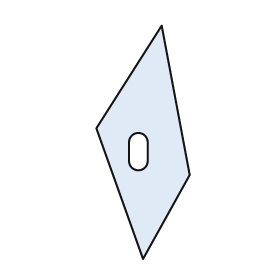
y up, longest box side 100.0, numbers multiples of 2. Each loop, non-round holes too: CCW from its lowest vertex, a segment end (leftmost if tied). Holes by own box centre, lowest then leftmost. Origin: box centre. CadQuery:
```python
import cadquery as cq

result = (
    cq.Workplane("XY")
    .moveTo(0.0, -50.0)
    .lineTo(20.0, -14.0)
    .lineTo(8.0, 50.0)
    .lineTo(-20.0, 6.0)
    .close()
    .moveTo(-6.0, -8.0)
    .threePointArc((-2.0, -12.0), (2.0, -8.0))
    .lineTo(2.0, 0.0)
    .threePointArc((-2.0, 4.0), (-6.0, 0.0))
    .close()
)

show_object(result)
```